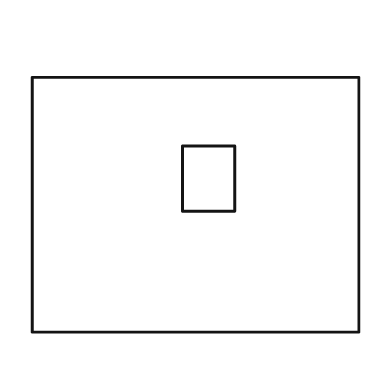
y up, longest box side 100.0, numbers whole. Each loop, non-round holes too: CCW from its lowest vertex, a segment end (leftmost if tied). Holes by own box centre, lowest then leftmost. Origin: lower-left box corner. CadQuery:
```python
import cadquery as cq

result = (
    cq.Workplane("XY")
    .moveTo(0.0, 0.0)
    .lineTo(100.0, 0.0)
    .lineTo(100.0, 78.0)
    .lineTo(0.0, 78.0)
    .close()
    .moveTo(46.0, 37.0)
    .lineTo(62.0, 37.0)
    .lineTo(62.0, 57.0)
    .lineTo(46.0, 57.0)
    .close()
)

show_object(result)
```